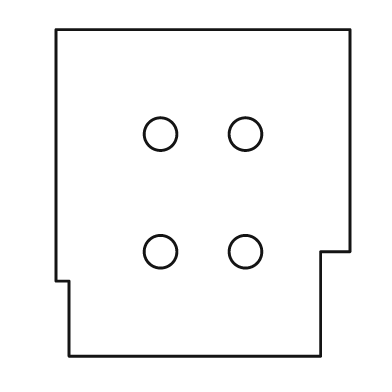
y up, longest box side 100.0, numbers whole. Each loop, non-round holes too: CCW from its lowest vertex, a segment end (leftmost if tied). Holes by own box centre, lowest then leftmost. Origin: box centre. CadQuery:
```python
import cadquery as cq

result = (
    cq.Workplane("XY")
    .moveTo(-41.0, -50.0)
    .lineTo(36.0, -50.0)
    .lineTo(36.0, -18.0)
    .lineTo(45.0, -18.0)
    .lineTo(45.0, 50.0)
    .lineTo(-45.0, 50.0)
    .lineTo(-45.0, -27.0)
    .lineTo(-41.0, -27.0)
    .close()
    .moveTo(-13.0, -18.0)
    .circle(5.0)
    .moveTo(13.0, -18.0)
    .circle(5.0)
    .moveTo(-13.0, 18.0)
    .circle(5.0)
    .moveTo(13.0, 18.0)
    .circle(5.0)
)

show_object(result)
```